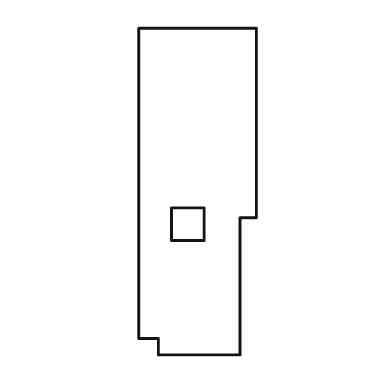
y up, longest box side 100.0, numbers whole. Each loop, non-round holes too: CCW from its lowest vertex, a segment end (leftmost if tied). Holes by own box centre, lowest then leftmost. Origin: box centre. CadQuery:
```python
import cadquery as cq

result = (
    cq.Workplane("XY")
    .moveTo(-12.0, -50.0)
    .lineTo(13.0, -50.0)
    .lineTo(13.0, -8.0)
    .lineTo(18.0, -8.0)
    .lineTo(18.0, 50.0)
    .lineTo(-18.0, 50.0)
    .lineTo(-18.0, -45.0)
    .lineTo(-12.0, -45.0)
    .close()
    .moveTo(-8.0, -15.0)
    .lineTo(2.0, -15.0)
    .lineTo(2.0, -5.0)
    .lineTo(-8.0, -5.0)
    .close()
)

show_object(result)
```